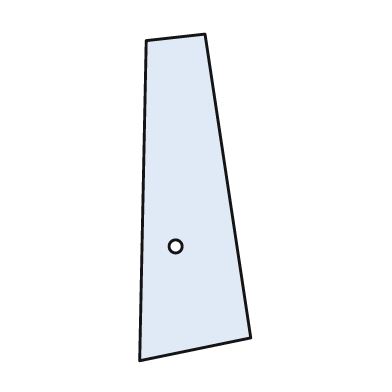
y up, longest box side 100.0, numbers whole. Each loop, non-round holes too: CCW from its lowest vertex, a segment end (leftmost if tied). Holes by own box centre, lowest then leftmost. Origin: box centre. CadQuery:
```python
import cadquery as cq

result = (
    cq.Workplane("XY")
    .moveTo(-17.0, -50.0)
    .lineTo(17.0, -43.0)
    .lineTo(3.0, 50.0)
    .lineTo(-15.0, 48.0)
    .close()
    .moveTo(-6.0, -15.0)
    .circle(2.0)
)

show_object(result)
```